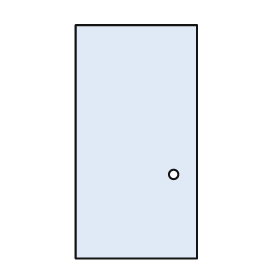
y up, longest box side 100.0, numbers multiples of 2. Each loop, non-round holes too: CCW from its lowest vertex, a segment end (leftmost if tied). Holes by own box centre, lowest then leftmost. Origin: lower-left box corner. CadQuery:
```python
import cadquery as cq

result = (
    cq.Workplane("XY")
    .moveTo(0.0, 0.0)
    .lineTo(52.0, 0.0)
    .lineTo(52.0, 100.0)
    .lineTo(0.0, 100.0)
    .close()
    .moveTo(42.0, 36.0)
    .circle(2.0)
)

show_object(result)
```